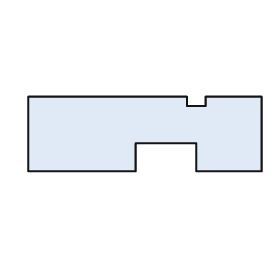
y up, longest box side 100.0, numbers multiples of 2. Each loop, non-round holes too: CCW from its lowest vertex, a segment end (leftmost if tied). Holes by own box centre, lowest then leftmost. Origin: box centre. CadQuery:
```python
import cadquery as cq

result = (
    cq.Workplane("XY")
    .moveTo(-50.0, -16.0)
    .lineTo(-4.0, -16.0)
    .lineTo(-4.0, -4.0)
    .lineTo(22.0, -4.0)
    .lineTo(22.0, -16.0)
    .lineTo(50.0, -16.0)
    .lineTo(50.0, 16.0)
    .lineTo(26.0, 16.0)
    .lineTo(26.0, 12.0)
    .lineTo(18.0, 12.0)
    .lineTo(18.0, 16.0)
    .lineTo(-50.0, 16.0)
    .close()
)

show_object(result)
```